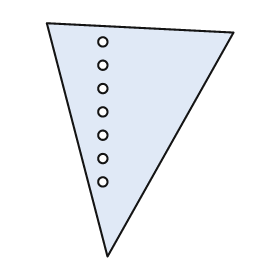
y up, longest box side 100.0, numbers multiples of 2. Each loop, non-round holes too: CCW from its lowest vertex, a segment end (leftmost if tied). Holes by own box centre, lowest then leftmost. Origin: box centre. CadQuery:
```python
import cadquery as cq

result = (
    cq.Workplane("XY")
    .moveTo(-14.0, -50.0)
    .lineTo(40.0, 46.0)
    .lineTo(-40.0, 50.0)
    .close()
    .moveTo(-16.0, -18.0)
    .circle(2.0)
    .moveTo(-16.0, -8.0)
    .circle(2.0)
    .moveTo(-16.0, 2.0)
    .circle(2.0)
    .moveTo(-16.0, 12.0)
    .circle(2.0)
    .moveTo(-16.0, 22.0)
    .circle(2.0)
    .moveTo(-16.0, 32.0)
    .circle(2.0)
    .moveTo(-16.0, 42.0)
    .circle(2.0)
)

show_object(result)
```